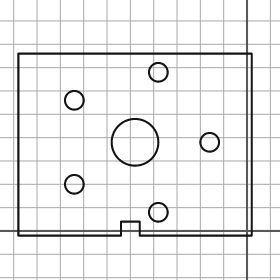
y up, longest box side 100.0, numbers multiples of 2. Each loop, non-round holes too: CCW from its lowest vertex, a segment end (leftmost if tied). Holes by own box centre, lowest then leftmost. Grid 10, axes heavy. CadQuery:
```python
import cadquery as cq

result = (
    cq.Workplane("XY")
    .moveTo(-98.0, -2.0)
    .lineTo(-54.0, -2.0)
    .lineTo(-54.0, 4.0)
    .lineTo(-46.0, 4.0)
    .lineTo(-46.0, -2.0)
    .lineTo(2.0, -2.0)
    .lineTo(2.0, 76.0)
    .lineTo(-98.0, 76.0)
    .close()
    .moveTo(-38.0, 8.0)
    .circle(4.0)
    .moveTo(-74.0, 20.0)
    .circle(4.0)
    .moveTo(-48.0, 38.0)
    .circle(10.0)
    .moveTo(-16.0, 38.0)
    .circle(4.0)
    .moveTo(-74.0, 56.0)
    .circle(4.0)
    .moveTo(-38.0, 68.0)
    .circle(4.0)
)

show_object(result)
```